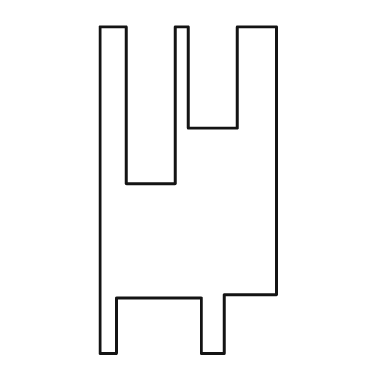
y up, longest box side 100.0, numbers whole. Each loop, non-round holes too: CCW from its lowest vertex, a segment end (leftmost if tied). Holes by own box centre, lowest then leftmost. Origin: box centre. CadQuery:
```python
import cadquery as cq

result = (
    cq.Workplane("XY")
    .moveTo(-27.0, -50.0)
    .lineTo(-22.0, -50.0)
    .lineTo(-22.0, -33.0)
    .lineTo(4.0, -33.0)
    .lineTo(4.0, -50.0)
    .lineTo(11.0, -50.0)
    .lineTo(11.0, -32.0)
    .lineTo(27.0, -32.0)
    .lineTo(27.0, 50.0)
    .lineTo(15.0, 50.0)
    .lineTo(15.0, 19.0)
    .lineTo(0.0, 19.0)
    .lineTo(0.0, 50.0)
    .lineTo(-4.0, 50.0)
    .lineTo(-4.0, 2.0)
    .lineTo(-19.0, 2.0)
    .lineTo(-19.0, 50.0)
    .lineTo(-27.0, 50.0)
    .close()
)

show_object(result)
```